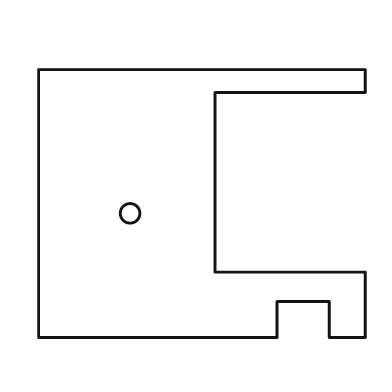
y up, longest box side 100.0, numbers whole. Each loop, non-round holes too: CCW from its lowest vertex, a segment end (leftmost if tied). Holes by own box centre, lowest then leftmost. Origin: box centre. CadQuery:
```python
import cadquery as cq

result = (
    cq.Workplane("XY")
    .moveTo(-50.0, -41.0)
    .lineTo(23.0, -41.0)
    .lineTo(23.0, -30.0)
    .lineTo(39.0, -30.0)
    .lineTo(39.0, -41.0)
    .lineTo(50.0, -41.0)
    .lineTo(50.0, -21.0)
    .lineTo(4.0, -21.0)
    .lineTo(4.0, 34.0)
    .lineTo(50.0, 34.0)
    .lineTo(50.0, 41.0)
    .lineTo(-50.0, 41.0)
    .close()
    .moveTo(-22.0, -3.0)
    .circle(3.0)
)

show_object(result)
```